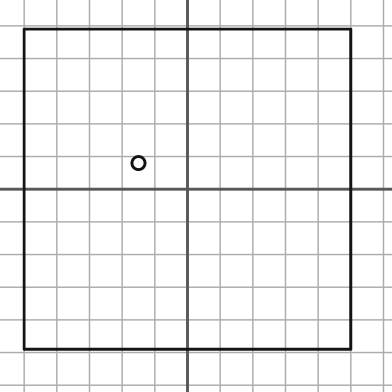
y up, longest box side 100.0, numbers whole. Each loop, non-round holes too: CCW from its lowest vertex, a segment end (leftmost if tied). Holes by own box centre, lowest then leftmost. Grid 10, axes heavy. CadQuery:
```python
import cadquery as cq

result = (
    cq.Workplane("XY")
    .moveTo(-50.0, -49.0)
    .lineTo(50.0, -49.0)
    .lineTo(50.0, 49.0)
    .lineTo(-50.0, 49.0)
    .close()
    .moveTo(-15.0, 8.0)
    .circle(2.0)
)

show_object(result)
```